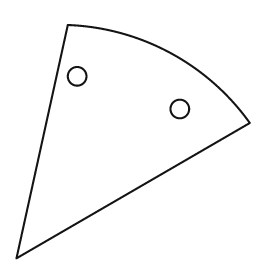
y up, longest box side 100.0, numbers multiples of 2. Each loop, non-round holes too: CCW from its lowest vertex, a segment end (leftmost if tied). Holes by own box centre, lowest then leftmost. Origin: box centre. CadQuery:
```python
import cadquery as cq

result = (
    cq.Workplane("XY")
    .moveTo(-50.0, -50.0)
    .lineTo(50.0, 8.0)
    .threePointArc((16.0, 38.0), (-28.0, 50.0))
    .close()
    .moveTo(20.0, 14.0)
    .circle(4.0)
    .moveTo(-24.0, 28.0)
    .circle(4.0)
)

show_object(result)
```